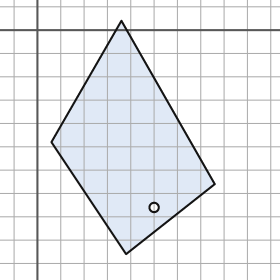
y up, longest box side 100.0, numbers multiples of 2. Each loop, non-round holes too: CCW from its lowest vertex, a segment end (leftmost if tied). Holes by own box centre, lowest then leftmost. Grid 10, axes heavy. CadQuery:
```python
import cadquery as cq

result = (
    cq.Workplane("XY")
    .moveTo(38.0, -96.0)
    .lineTo(76.0, -66.0)
    .lineTo(36.0, 4.0)
    .lineTo(6.0, -48.0)
    .close()
    .moveTo(50.0, -76.0)
    .circle(2.0)
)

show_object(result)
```